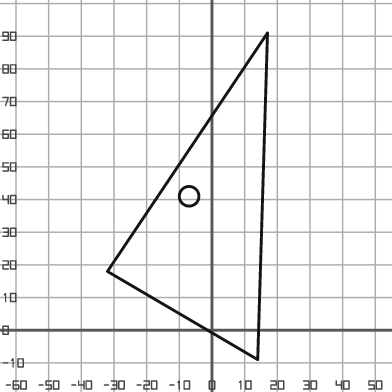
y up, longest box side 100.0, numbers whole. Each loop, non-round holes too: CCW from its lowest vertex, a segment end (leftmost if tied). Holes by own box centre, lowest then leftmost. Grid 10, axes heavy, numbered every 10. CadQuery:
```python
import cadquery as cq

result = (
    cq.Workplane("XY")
    .moveTo(14.0, -9.0)
    .lineTo(17.0, 91.0)
    .lineTo(-32.0, 18.0)
    .close()
    .moveTo(-7.0, 41.0)
    .circle(3.0)
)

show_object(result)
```